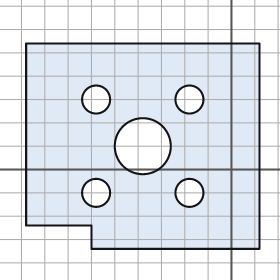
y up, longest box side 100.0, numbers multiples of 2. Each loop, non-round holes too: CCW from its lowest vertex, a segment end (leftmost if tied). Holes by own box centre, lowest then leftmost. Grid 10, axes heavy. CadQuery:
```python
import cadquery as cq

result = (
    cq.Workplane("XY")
    .moveTo(-60.0, -34.0)
    .lineTo(12.0, -34.0)
    .lineTo(12.0, 54.0)
    .lineTo(-88.0, 54.0)
    .lineTo(-88.0, -24.0)
    .lineTo(-60.0, -24.0)
    .close()
    .moveTo(-58.0, -10.0)
    .circle(6.0)
    .moveTo(-18.0, -10.0)
    .circle(6.0)
    .moveTo(-38.0, 10.0)
    .circle(12.0)
    .moveTo(-58.0, 30.0)
    .circle(6.0)
    .moveTo(-18.0, 30.0)
    .circle(6.0)
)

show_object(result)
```